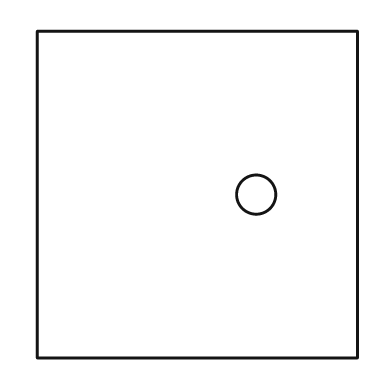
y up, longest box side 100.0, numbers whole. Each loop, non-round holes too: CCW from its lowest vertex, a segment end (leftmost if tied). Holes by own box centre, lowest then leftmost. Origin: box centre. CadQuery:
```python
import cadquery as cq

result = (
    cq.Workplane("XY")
    .moveTo(-49.0, -50.0)
    .lineTo(49.0, -50.0)
    .lineTo(49.0, 50.0)
    .lineTo(-49.0, 50.0)
    .close()
    .moveTo(18.0, 0.0)
    .circle(6.0)
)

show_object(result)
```